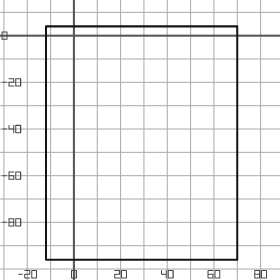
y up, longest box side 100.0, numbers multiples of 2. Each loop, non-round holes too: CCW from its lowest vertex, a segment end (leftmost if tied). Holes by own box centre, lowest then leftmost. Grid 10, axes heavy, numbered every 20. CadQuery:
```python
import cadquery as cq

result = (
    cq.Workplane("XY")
    .moveTo(-12.0, -96.0)
    .lineTo(70.0, -96.0)
    .lineTo(70.0, 4.0)
    .lineTo(-12.0, 4.0)
    .close()
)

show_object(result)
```